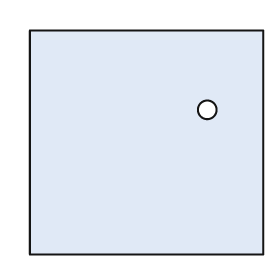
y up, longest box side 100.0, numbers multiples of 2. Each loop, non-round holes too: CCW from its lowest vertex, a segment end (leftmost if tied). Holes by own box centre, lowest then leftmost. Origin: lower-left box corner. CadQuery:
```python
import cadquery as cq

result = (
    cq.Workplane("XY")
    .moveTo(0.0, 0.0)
    .lineTo(100.0, 0.0)
    .lineTo(100.0, 96.0)
    .lineTo(0.0, 96.0)
    .close()
    .moveTo(76.0, 62.0)
    .circle(4.0)
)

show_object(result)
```